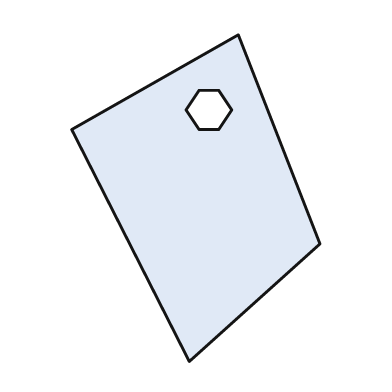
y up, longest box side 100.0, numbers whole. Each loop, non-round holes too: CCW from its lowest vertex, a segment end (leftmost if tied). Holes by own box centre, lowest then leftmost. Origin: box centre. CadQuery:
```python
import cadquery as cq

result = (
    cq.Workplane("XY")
    .moveTo(-2.0, -50.0)
    .lineTo(38.0, -14.0)
    .lineTo(13.0, 50.0)
    .lineTo(-38.0, 21.0)
    .close()
    .moveTo(1.0, 21.0)
    .lineTo(7.0, 21.0)
    .lineTo(11.0, 27.0)
    .lineTo(7.0, 33.0)
    .lineTo(1.0, 33.0)
    .lineTo(-3.0, 27.0)
    .close()
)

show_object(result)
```